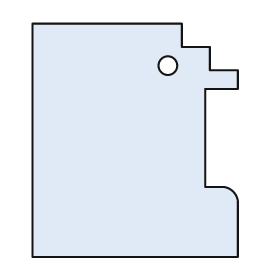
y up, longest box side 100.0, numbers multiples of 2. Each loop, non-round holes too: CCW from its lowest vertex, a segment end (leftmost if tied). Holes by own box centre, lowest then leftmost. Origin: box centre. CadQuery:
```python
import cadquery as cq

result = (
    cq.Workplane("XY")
    .moveTo(-44.0, -50.0)
    .lineTo(44.0, -50.0)
    .lineTo(44.0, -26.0)
    .threePointArc((42.0, -22.0), (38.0, -20.0))
    .lineTo(30.0, -20.0)
    .lineTo(30.0, 22.0)
    .lineTo(44.0, 22.0)
    .lineTo(44.0, 30.0)
    .lineTo(32.0, 30.0)
    .lineTo(32.0, 40.0)
    .lineTo(20.0, 40.0)
    .lineTo(20.0, 50.0)
    .lineTo(-44.0, 50.0)
    .close()
    .moveTo(14.0, 32.0)
    .circle(4.0)
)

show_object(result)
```